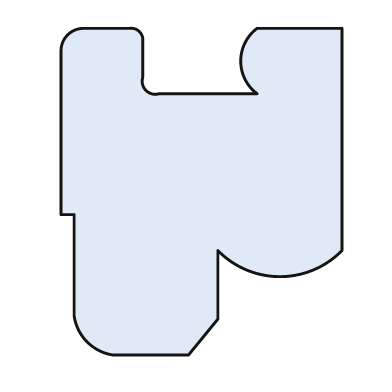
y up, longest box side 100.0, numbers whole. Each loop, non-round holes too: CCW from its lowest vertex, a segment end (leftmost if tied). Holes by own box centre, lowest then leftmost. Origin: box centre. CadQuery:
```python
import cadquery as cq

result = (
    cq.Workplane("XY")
    .moveTo(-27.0, -50.0)
    .lineTo(-4.0, -50.0)
    .lineTo(5.0, -39.0)
    .lineTo(5.0, -18.0)
    .threePointArc((24.0, -26.0), (43.0, -18.0))
    .lineTo(43.0, 50.0)
    .lineTo(17.0, 50.0)
    .threePointArc((12.0, 40.0), (17.0, 30.0))
    .lineTo(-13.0, 30.0)
    .threePointArc((-17.0, 31.0), (-18.0, 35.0))
    .lineTo(-18.0, 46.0)
    .threePointArc((-19.0, 49.0), (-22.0, 50.0))
    .lineTo(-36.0, 50.0)
    .threePointArc((-41.0, 48.0), (-43.0, 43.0))
    .lineTo(-43.0, -7.0)
    .lineTo(-39.0, -7.0)
    .lineTo(-39.0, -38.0)
    .threePointArc((-35.0, -46.0), (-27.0, -50.0))
    .close()
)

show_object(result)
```